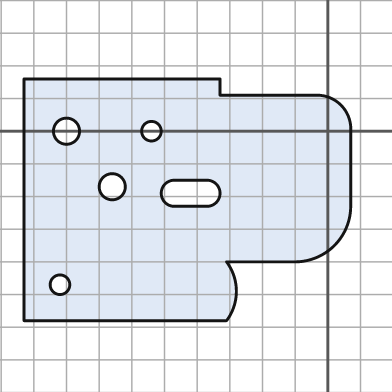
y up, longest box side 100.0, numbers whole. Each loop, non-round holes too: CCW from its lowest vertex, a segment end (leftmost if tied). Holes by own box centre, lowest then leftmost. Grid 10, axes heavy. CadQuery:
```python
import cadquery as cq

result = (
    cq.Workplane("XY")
    .moveTo(-93.0, -58.0)
    .lineTo(-31.0, -58.0)
    .threePointArc((-28.0, -49.0), (-31.0, -40.0))
    .lineTo(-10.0, -40.0)
    .threePointArc((2.0, -35.0), (7.0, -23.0))
    .lineTo(7.0, 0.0)
    .threePointArc((4.0, 8.0), (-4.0, 11.0))
    .lineTo(-33.0, 11.0)
    .lineTo(-33.0, 16.0)
    .lineTo(-93.0, 16.0)
    .close()
    .moveTo(-82.0, -47.0)
    .circle(3.0)
    .moveTo(-47.0, -23.0)
    .lineTo(-37.0, -23.0)
    .threePointArc((-33.0, -19.0), (-37.0, -15.0))
    .lineTo(-47.0, -15.0)
    .threePointArc((-51.0, -19.0), (-47.0, -23.0))
    .close()
    .moveTo(-66.0, -17.0)
    .circle(4.0)
    .moveTo(-80.0, 0.0)
    .circle(4.0)
    .moveTo(-54.0, 0.0)
    .circle(3.0)
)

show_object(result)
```